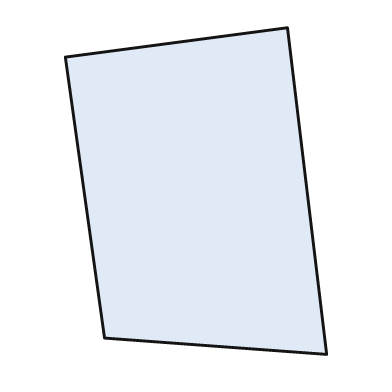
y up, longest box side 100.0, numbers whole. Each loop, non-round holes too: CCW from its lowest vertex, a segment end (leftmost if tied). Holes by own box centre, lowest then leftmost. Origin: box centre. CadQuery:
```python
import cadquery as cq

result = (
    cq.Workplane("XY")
    .moveTo(40.0, -50.0)
    .lineTo(28.0, 50.0)
    .lineTo(-40.0, 41.0)
    .lineTo(-28.0, -45.0)
    .close()
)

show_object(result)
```